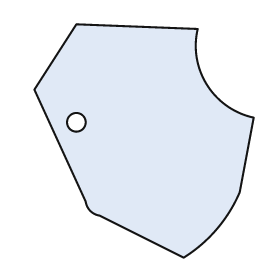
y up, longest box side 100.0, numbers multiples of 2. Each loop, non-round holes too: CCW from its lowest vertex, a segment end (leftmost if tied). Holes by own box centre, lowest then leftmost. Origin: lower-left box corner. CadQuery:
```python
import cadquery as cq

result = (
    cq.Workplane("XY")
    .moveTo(64.0, 0.0)
    .threePointArc((78.0, 12.0), (88.0, 28.0))
    .lineTo(94.0, 60.0)
    .threePointArc((74.0, 74.0), (70.0, 98.0))
    .lineTo(18.0, 100.0)
    .lineTo(0.0, 72.0)
    .lineTo(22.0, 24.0)
    .threePointArc((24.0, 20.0), (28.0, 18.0))
    .close()
    .moveTo(18.0, 58.0)
    .circle(4.0)
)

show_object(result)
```